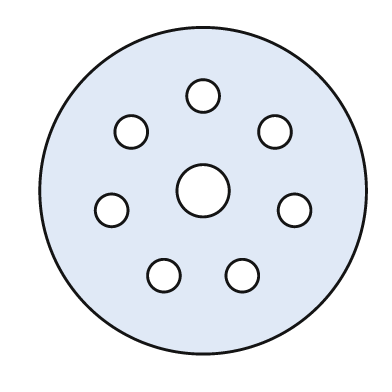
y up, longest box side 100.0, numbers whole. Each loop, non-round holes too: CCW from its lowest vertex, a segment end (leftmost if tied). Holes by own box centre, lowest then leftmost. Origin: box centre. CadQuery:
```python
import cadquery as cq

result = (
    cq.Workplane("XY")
    .moveTo(0.0, 0.0)
    .circle(50.0)
    .moveTo(-12.0, -26.0)
    .circle(5.0)
    .moveTo(12.0, -26.0)
    .circle(5.0)
    .moveTo(-28.0, -6.0)
    .circle(5.0)
    .moveTo(28.0, -6.0)
    .circle(5.0)
    .moveTo(0.0, 0.0)
    .circle(8.0)
    .moveTo(-22.0, 18.0)
    .circle(5.0)
    .moveTo(22.0, 18.0)
    .circle(5.0)
    .moveTo(0.0, 29.0)
    .circle(5.0)
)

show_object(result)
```